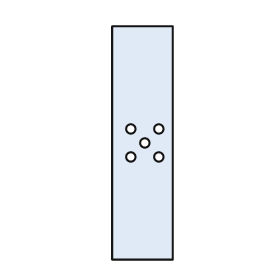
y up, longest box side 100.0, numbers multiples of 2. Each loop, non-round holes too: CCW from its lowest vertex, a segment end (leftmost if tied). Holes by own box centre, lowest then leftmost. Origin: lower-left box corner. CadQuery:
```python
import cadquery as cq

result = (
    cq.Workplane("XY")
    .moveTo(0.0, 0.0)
    .lineTo(26.0, 0.0)
    .lineTo(26.0, 100.0)
    .lineTo(0.0, 100.0)
    .close()
    .moveTo(8.0, 44.0)
    .circle(2.0)
    .moveTo(20.0, 44.0)
    .circle(2.0)
    .moveTo(14.0, 50.0)
    .circle(2.0)
    .moveTo(8.0, 56.0)
    .circle(2.0)
    .moveTo(20.0, 56.0)
    .circle(2.0)
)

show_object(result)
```